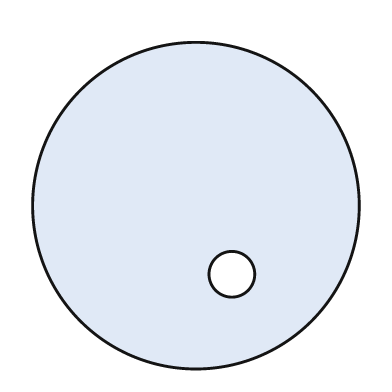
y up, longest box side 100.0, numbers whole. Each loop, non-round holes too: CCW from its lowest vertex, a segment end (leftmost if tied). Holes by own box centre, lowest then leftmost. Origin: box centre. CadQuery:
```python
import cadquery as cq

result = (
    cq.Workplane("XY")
    .moveTo(0.0, 0.0)
    .circle(50.0)
    .moveTo(11.0, -21.0)
    .circle(7.0)
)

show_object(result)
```